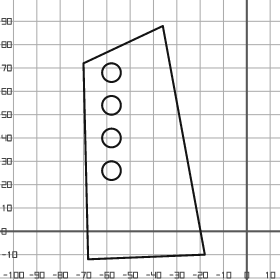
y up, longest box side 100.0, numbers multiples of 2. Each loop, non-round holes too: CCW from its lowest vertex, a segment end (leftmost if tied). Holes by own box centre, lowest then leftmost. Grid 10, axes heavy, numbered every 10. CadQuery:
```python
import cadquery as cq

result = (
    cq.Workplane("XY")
    .moveTo(-68.0, -12.0)
    .lineTo(-18.0, -10.0)
    .lineTo(-36.0, 88.0)
    .lineTo(-70.0, 72.0)
    .close()
    .moveTo(-58.0, 26.0)
    .circle(4.0)
    .moveTo(-58.0, 40.0)
    .circle(4.0)
    .moveTo(-58.0, 54.0)
    .circle(4.0)
    .moveTo(-58.0, 68.0)
    .circle(4.0)
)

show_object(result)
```